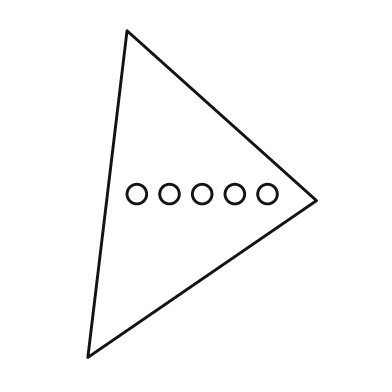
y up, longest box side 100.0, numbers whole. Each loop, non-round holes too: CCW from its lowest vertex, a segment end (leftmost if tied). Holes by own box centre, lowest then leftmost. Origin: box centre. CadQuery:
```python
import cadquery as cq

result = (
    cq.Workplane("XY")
    .moveTo(-35.0, -50.0)
    .lineTo(35.0, -2.0)
    .lineTo(-23.0, 50.0)
    .close()
    .moveTo(-20.0, 0.0)
    .circle(3.0)
    .moveTo(-10.0, 0.0)
    .circle(3.0)
    .moveTo(0.0, 0.0)
    .circle(3.0)
    .moveTo(10.0, 0.0)
    .circle(3.0)
    .moveTo(20.0, 0.0)
    .circle(3.0)
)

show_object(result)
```